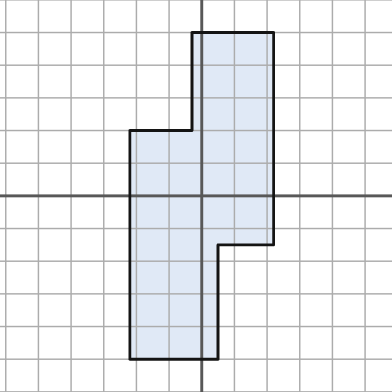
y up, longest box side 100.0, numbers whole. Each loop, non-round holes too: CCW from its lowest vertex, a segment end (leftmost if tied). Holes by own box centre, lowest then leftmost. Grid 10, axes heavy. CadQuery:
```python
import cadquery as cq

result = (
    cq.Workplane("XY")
    .moveTo(-22.0, -50.0)
    .lineTo(5.0, -50.0)
    .lineTo(5.0, -15.0)
    .lineTo(22.0, -15.0)
    .lineTo(22.0, 50.0)
    .lineTo(-3.0, 50.0)
    .lineTo(-3.0, 20.0)
    .lineTo(-22.0, 20.0)
    .close()
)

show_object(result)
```